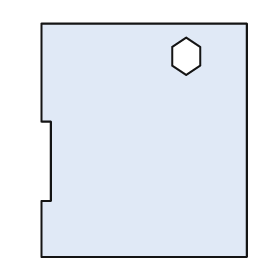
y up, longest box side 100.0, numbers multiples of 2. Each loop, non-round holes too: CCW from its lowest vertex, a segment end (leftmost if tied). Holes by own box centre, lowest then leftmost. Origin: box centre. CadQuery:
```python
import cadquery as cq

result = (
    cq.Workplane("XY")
    .moveTo(-44.0, -50.0)
    .lineTo(44.0, -50.0)
    .lineTo(44.0, 50.0)
    .lineTo(-44.0, 50.0)
    .lineTo(-44.0, 8.0)
    .lineTo(-40.0, 8.0)
    .lineTo(-40.0, -26.0)
    .lineTo(-44.0, -26.0)
    .close()
    .moveTo(18.0, 28.0)
    .lineTo(24.0, 32.0)
    .lineTo(24.0, 40.0)
    .lineTo(18.0, 44.0)
    .lineTo(12.0, 40.0)
    .lineTo(12.0, 32.0)
    .close()
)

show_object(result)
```